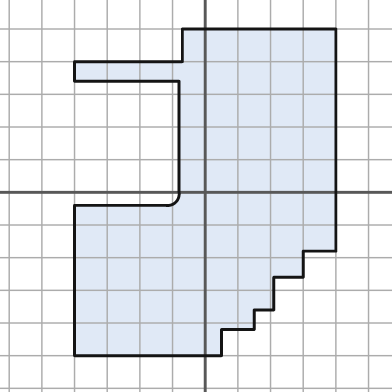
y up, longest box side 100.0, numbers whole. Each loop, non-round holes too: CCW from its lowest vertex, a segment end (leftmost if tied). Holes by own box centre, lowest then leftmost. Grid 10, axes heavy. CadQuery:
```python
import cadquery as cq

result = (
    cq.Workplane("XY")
    .moveTo(-40.0, -50.0)
    .lineTo(5.0, -50.0)
    .lineTo(5.0, -42.0)
    .lineTo(15.0, -42.0)
    .lineTo(15.0, -36.0)
    .lineTo(21.0, -36.0)
    .lineTo(21.0, -26.0)
    .lineTo(30.0, -26.0)
    .lineTo(30.0, -18.0)
    .lineTo(40.0, -18.0)
    .lineTo(40.0, 50.0)
    .lineTo(-7.0, 50.0)
    .lineTo(-7.0, 40.0)
    .lineTo(-40.0, 40.0)
    .lineTo(-40.0, 34.0)
    .lineTo(-8.0, 34.0)
    .lineTo(-8.0, 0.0)
    .threePointArc((-9.0, -3.0), (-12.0, -4.0))
    .lineTo(-40.0, -4.0)
    .close()
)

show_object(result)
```